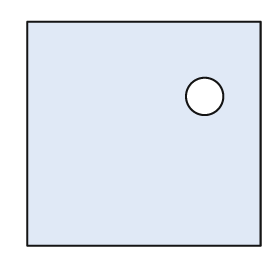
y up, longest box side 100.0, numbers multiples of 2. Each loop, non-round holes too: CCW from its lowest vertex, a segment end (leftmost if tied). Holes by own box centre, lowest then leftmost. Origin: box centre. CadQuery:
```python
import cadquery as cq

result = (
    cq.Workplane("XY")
    .moveTo(-50.0, -48.0)
    .lineTo(50.0, -48.0)
    .lineTo(50.0, 48.0)
    .lineTo(-50.0, 48.0)
    .close()
    .moveTo(26.0, 16.0)
    .circle(8.0)
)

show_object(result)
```